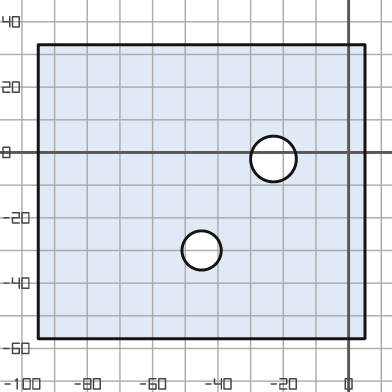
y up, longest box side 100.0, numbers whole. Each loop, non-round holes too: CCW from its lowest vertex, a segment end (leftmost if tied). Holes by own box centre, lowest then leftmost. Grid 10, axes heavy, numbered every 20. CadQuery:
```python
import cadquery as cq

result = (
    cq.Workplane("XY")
    .moveTo(-95.0, -57.0)
    .lineTo(5.0, -57.0)
    .lineTo(5.0, 33.0)
    .lineTo(-95.0, 33.0)
    .close()
    .moveTo(-45.0, -30.0)
    .circle(6.0)
    .moveTo(-23.0, -2.0)
    .circle(7.0)
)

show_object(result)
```